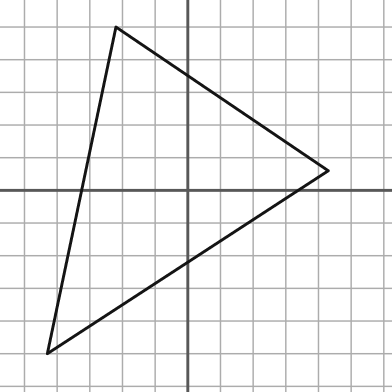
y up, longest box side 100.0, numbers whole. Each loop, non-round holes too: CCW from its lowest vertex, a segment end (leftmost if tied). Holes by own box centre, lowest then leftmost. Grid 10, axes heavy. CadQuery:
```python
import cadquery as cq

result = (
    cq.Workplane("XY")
    .moveTo(-43.0, -50.0)
    .lineTo(43.0, 6.0)
    .lineTo(-22.0, 50.0)
    .close()
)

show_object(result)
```